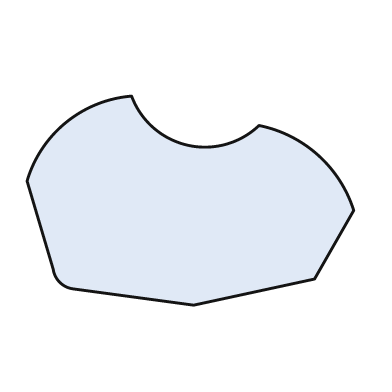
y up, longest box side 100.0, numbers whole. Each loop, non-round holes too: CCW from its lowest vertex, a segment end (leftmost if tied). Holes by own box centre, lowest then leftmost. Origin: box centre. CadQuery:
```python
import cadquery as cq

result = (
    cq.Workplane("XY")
    .moveTo(1.0, -32.0)
    .lineTo(38.0, -24.0)
    .lineTo(50.0, -3.0)
    .threePointArc((39.0, 14.0), (21.0, 23.0))
    .threePointArc((-1.0, 17.0), (-18.0, 32.0))
    .threePointArc((-38.0, 24.0), (-50.0, 6.0))
    .lineTo(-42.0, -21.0)
    .threePointArc((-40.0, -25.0), (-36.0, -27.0))
    .close()
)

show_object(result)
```